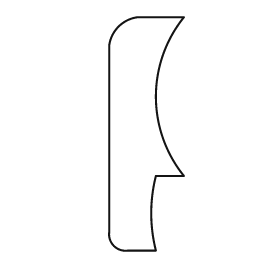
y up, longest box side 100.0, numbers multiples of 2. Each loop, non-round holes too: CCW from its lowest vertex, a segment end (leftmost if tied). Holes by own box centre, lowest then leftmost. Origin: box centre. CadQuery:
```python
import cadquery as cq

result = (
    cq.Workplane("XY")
    .moveTo(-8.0, -50.0)
    .lineTo(4.0, -50.0)
    .threePointArc((2.0, -34.0), (4.0, -18.0))
    .lineTo(16.0, -18.0)
    .threePointArc((4.0, 16.0), (16.0, 50.0))
    .lineTo(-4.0, 50.0)
    .threePointArc((-12.0, 46.0), (-16.0, 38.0))
    .lineTo(-16.0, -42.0)
    .threePointArc((-14.0, -48.0), (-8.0, -50.0))
    .close()
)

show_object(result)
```